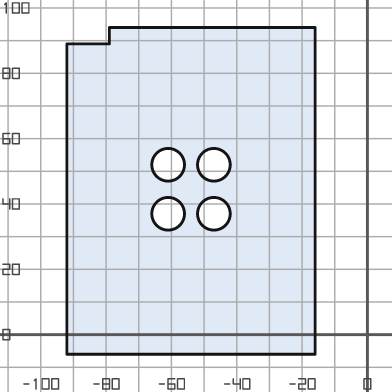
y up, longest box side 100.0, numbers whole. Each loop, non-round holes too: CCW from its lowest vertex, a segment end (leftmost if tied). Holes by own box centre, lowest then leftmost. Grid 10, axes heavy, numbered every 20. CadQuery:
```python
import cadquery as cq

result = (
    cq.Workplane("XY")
    .moveTo(-92.0, -6.0)
    .lineTo(-16.0, -6.0)
    .lineTo(-16.0, 94.0)
    .lineTo(-79.0, 94.0)
    .lineTo(-79.0, 89.0)
    .lineTo(-92.0, 89.0)
    .close()
    .moveTo(-61.0, 37.0)
    .circle(5.0)
    .moveTo(-47.0, 37.0)
    .circle(5.0)
    .moveTo(-61.0, 52.0)
    .circle(5.0)
    .moveTo(-47.0, 52.0)
    .circle(5.0)
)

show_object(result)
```